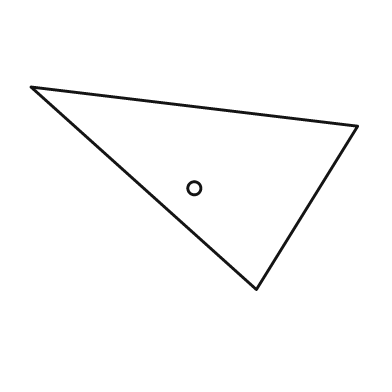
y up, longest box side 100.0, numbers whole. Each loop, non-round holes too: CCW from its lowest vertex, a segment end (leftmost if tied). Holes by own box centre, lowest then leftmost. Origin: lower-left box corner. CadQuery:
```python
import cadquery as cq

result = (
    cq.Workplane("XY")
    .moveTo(69.0, 0.0)
    .lineTo(100.0, 50.0)
    .lineTo(0.0, 62.0)
    .close()
    .moveTo(50.0, 31.0)
    .circle(2.0)
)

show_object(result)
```